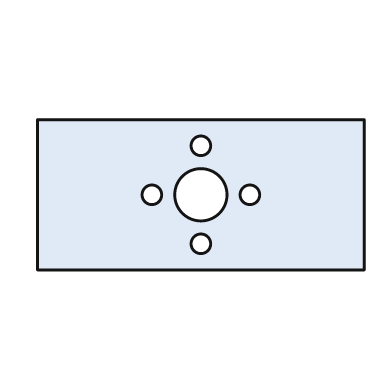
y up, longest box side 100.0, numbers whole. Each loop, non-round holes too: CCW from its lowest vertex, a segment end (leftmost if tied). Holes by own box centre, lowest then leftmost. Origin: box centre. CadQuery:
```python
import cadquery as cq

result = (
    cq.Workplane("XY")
    .moveTo(-50.0, -23.0)
    .lineTo(50.0, -23.0)
    .lineTo(50.0, 23.0)
    .lineTo(-50.0, 23.0)
    .close()
    .moveTo(0.0, -15.0)
    .circle(3.0)
    .moveTo(-15.0, 0.0)
    .circle(3.0)
    .moveTo(0.0, 0.0)
    .circle(8.0)
    .moveTo(15.0, 0.0)
    .circle(3.0)
    .moveTo(0.0, 15.0)
    .circle(3.0)
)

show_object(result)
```